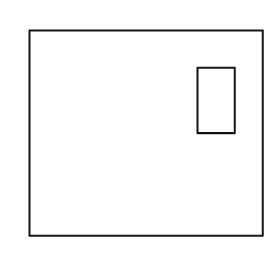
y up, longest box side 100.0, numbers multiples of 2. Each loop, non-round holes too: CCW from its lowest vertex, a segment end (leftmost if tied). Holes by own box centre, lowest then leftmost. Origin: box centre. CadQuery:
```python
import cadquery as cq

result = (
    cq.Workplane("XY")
    .moveTo(-50.0, -44.0)
    .lineTo(50.0, -44.0)
    .lineTo(50.0, 44.0)
    .lineTo(-50.0, 44.0)
    .close()
    .moveTo(22.0, 0.0)
    .lineTo(38.0, 0.0)
    .lineTo(38.0, 28.0)
    .lineTo(22.0, 28.0)
    .close()
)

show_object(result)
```